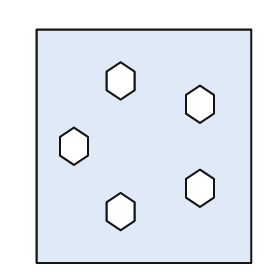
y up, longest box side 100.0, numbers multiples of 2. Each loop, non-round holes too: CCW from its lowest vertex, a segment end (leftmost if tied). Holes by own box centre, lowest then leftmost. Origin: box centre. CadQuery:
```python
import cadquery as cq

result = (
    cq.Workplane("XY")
    .moveTo(-46.0, -50.0)
    .lineTo(46.0, -50.0)
    .lineTo(46.0, 50.0)
    .lineTo(-46.0, 50.0)
    .close()
    .moveTo(-10.0, -36.0)
    .lineTo(-4.0, -32.0)
    .lineTo(-4.0, -24.0)
    .lineTo(-10.0, -20.0)
    .lineTo(-16.0, -24.0)
    .lineTo(-16.0, -32.0)
    .close()
    .moveTo(24.0, -26.0)
    .lineTo(30.0, -22.0)
    .lineTo(30.0, -14.0)
    .lineTo(24.0, -10.0)
    .lineTo(18.0, -14.0)
    .lineTo(18.0, -22.0)
    .close()
    .moveTo(-30.0, -8.0)
    .lineTo(-24.0, -4.0)
    .lineTo(-24.0, 4.0)
    .lineTo(-30.0, 8.0)
    .lineTo(-36.0, 4.0)
    .lineTo(-36.0, -4.0)
    .close()
    .moveTo(24.0, 10.0)
    .lineTo(30.0, 14.0)
    .lineTo(30.0, 22.0)
    .lineTo(24.0, 26.0)
    .lineTo(18.0, 22.0)
    .lineTo(18.0, 14.0)
    .close()
    .moveTo(-10.0, 20.0)
    .lineTo(-4.0, 24.0)
    .lineTo(-4.0, 32.0)
    .lineTo(-10.0, 36.0)
    .lineTo(-16.0, 32.0)
    .lineTo(-16.0, 24.0)
    .close()
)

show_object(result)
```